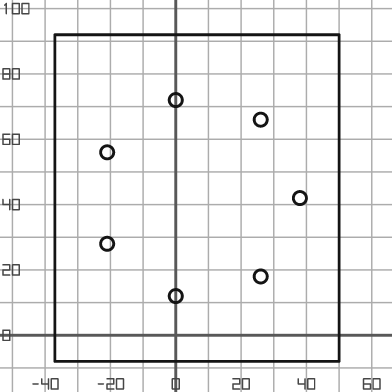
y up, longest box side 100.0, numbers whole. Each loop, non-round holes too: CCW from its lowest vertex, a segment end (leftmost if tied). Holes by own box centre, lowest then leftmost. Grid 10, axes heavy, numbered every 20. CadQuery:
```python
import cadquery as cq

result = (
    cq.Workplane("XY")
    .moveTo(-37.0, -8.0)
    .lineTo(50.0, -8.0)
    .lineTo(50.0, 92.0)
    .lineTo(-37.0, 92.0)
    .close()
    .moveTo(0.0, 12.0)
    .circle(2.0)
    .moveTo(26.0, 18.0)
    .circle(2.0)
    .moveTo(-21.0, 28.0)
    .circle(2.0)
    .moveTo(38.0, 42.0)
    .circle(2.0)
    .moveTo(-21.0, 56.0)
    .circle(2.0)
    .moveTo(26.0, 66.0)
    .circle(2.0)
    .moveTo(0.0, 72.0)
    .circle(2.0)
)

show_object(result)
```